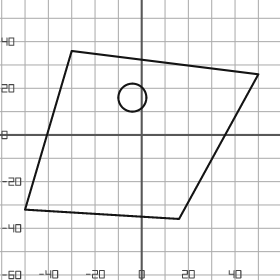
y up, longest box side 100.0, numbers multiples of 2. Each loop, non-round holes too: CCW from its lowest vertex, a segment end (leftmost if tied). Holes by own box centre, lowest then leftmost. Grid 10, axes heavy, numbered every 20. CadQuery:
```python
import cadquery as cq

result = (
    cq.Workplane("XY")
    .moveTo(16.0, -36.0)
    .lineTo(50.0, 26.0)
    .lineTo(-30.0, 36.0)
    .lineTo(-50.0, -32.0)
    .close()
    .moveTo(-4.0, 16.0)
    .circle(6.0)
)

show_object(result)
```